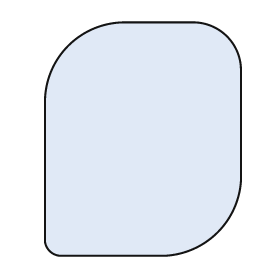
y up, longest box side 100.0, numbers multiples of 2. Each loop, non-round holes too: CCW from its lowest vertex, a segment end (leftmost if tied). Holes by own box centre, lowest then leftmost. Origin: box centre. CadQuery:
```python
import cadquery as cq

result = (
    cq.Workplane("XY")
    .moveTo(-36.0, -50.0)
    .lineTo(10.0, -50.0)
    .threePointArc((32.0, -40.0), (42.0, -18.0))
    .lineTo(42.0, 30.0)
    .threePointArc((36.0, 44.0), (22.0, 50.0))
    .lineTo(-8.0, 50.0)
    .threePointArc((-32.0, 40.0), (-42.0, 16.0))
    .lineTo(-42.0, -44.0)
    .threePointArc((-40.0, -48.0), (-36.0, -50.0))
    .close()
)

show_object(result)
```